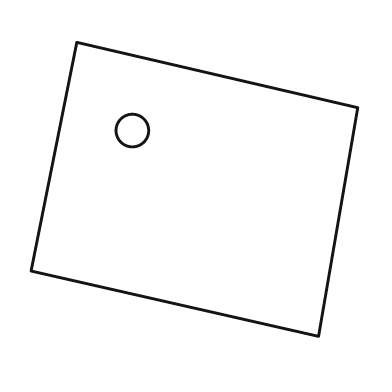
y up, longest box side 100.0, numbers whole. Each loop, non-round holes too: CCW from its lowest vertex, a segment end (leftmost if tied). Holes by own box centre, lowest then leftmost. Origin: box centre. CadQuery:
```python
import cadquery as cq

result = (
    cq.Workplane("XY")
    .moveTo(38.0, -45.0)
    .lineTo(50.0, 25.0)
    .lineTo(-36.0, 45.0)
    .lineTo(-50.0, -25.0)
    .close()
    .moveTo(-19.0, 18.0)
    .circle(5.0)
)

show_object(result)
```